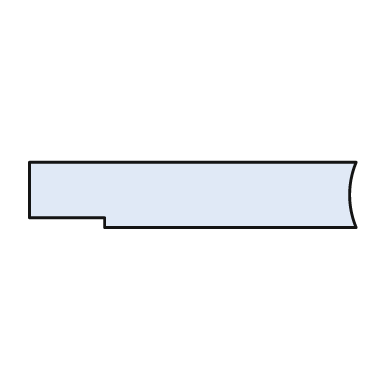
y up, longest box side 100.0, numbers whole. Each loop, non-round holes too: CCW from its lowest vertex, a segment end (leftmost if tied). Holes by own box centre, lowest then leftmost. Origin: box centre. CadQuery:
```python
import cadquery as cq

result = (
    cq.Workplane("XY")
    .moveTo(-27.0, -10.0)
    .lineTo(50.0, -10.0)
    .threePointArc((48.0, 0.0), (50.0, 10.0))
    .lineTo(-50.0, 10.0)
    .lineTo(-50.0, -7.0)
    .lineTo(-27.0, -7.0)
    .close()
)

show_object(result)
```